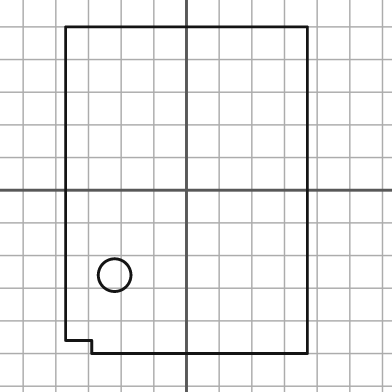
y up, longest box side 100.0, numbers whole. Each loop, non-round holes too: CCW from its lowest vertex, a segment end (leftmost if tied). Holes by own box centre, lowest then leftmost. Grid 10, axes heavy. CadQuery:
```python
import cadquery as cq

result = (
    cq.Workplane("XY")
    .moveTo(-29.0, -50.0)
    .lineTo(37.0, -50.0)
    .lineTo(37.0, 50.0)
    .lineTo(-37.0, 50.0)
    .lineTo(-37.0, -46.0)
    .lineTo(-29.0, -46.0)
    .close()
    .moveTo(-22.0, -26.0)
    .circle(5.0)
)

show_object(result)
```